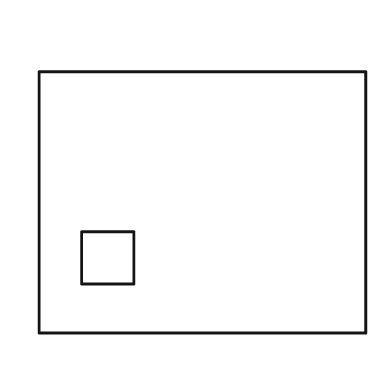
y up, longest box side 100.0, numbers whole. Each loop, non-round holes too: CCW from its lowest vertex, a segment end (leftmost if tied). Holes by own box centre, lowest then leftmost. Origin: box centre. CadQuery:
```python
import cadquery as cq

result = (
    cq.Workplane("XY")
    .moveTo(-50.0, -40.0)
    .lineTo(50.0, -40.0)
    .lineTo(50.0, 40.0)
    .lineTo(-50.0, 40.0)
    .close()
    .moveTo(-37.0, -25.0)
    .lineTo(-21.0, -25.0)
    .lineTo(-21.0, -9.0)
    .lineTo(-37.0, -9.0)
    .close()
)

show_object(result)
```